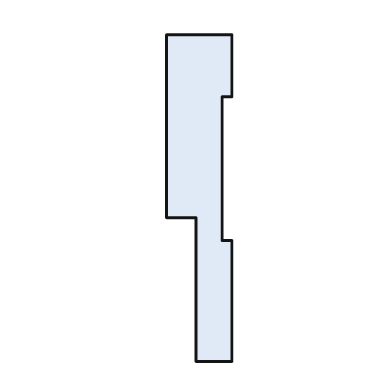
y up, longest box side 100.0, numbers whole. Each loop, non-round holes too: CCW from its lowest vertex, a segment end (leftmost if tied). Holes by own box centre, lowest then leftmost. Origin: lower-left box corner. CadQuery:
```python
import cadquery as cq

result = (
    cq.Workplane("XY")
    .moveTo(9.0, 0.0)
    .lineTo(20.0, 0.0)
    .lineTo(20.0, 37.0)
    .lineTo(17.0, 37.0)
    .lineTo(17.0, 81.0)
    .lineTo(20.0, 81.0)
    .lineTo(20.0, 100.0)
    .lineTo(0.0, 100.0)
    .lineTo(0.0, 44.0)
    .lineTo(9.0, 44.0)
    .close()
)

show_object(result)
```